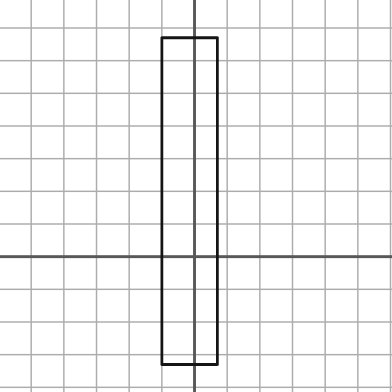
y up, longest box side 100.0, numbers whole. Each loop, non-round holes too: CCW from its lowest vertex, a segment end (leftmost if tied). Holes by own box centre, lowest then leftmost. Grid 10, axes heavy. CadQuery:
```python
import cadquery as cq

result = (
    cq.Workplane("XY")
    .moveTo(-10.0, -33.0)
    .lineTo(7.0, -33.0)
    .lineTo(7.0, 67.0)
    .lineTo(-10.0, 67.0)
    .close()
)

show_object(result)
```